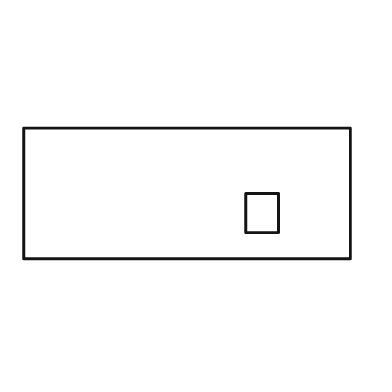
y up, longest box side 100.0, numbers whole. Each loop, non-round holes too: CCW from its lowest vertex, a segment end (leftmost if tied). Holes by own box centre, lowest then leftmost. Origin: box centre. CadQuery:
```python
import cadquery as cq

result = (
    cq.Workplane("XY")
    .moveTo(-50.0, -20.0)
    .lineTo(50.0, -20.0)
    .lineTo(50.0, 20.0)
    .lineTo(-50.0, 20.0)
    .close()
    .moveTo(18.0, -12.0)
    .lineTo(28.0, -12.0)
    .lineTo(28.0, 0.0)
    .lineTo(18.0, 0.0)
    .close()
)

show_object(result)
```